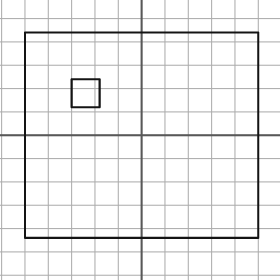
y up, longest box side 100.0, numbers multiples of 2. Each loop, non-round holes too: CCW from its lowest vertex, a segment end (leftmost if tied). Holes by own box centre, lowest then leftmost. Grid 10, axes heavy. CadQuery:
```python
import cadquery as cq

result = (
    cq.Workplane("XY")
    .moveTo(-50.0, -44.0)
    .lineTo(50.0, -44.0)
    .lineTo(50.0, 44.0)
    .lineTo(-50.0, 44.0)
    .close()
    .moveTo(-30.0, 12.0)
    .lineTo(-18.0, 12.0)
    .lineTo(-18.0, 24.0)
    .lineTo(-30.0, 24.0)
    .close()
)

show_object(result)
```